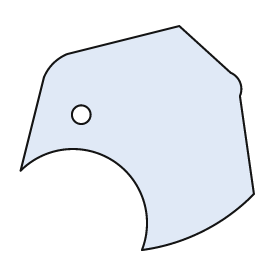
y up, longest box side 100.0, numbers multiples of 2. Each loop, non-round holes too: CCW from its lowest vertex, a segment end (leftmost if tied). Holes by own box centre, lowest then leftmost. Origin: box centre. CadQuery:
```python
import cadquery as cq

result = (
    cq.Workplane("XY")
    .moveTo(2.0, -48.0)
    .threePointArc((28.0, -40.0), (50.0, -24.0))
    .lineTo(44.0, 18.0)
    .threePointArc((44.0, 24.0), (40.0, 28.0))
    .lineTo(18.0, 48.0)
    .lineTo(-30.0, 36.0)
    .threePointArc((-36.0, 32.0), (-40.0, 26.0))
    .lineTo(-50.0, -14.0)
    .threePointArc((-10.0, -10.0), (2.0, -48.0))
    .close()
    .moveTo(-24.0, 10.0)
    .circle(4.0)
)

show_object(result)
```